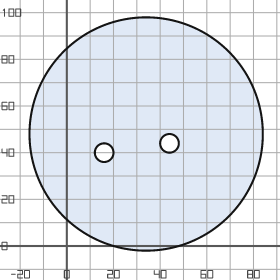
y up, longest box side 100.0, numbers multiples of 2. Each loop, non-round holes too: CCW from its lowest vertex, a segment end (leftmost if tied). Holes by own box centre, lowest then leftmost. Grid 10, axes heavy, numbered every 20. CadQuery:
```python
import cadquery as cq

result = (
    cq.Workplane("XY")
    .moveTo(34.0, 48.0)
    .circle(50.0)
    .moveTo(16.0, 40.0)
    .circle(4.0)
    .moveTo(44.0, 44.0)
    .circle(4.0)
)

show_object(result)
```